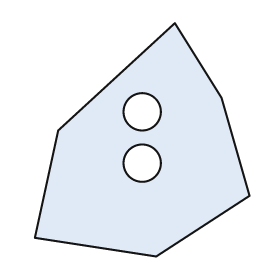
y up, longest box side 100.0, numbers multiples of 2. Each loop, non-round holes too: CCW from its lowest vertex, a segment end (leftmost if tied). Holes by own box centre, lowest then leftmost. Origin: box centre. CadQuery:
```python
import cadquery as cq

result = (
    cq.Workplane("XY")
    .moveTo(6.0, -50.0)
    .lineTo(46.0, -24.0)
    .lineTo(34.0, 18.0)
    .lineTo(14.0, 50.0)
    .lineTo(-36.0, 4.0)
    .lineTo(-46.0, -42.0)
    .close()
    .moveTo(0.0, -10.0)
    .circle(8.0)
    .moveTo(0.0, 12.0)
    .circle(8.0)
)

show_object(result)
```